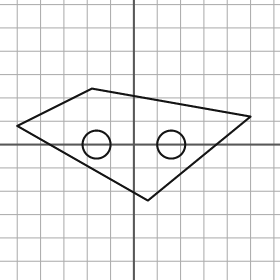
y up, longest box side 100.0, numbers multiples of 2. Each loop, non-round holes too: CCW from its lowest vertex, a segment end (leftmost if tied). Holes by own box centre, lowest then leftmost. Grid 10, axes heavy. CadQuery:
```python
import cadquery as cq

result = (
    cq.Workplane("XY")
    .moveTo(6.0, -24.0)
    .lineTo(50.0, 12.0)
    .lineTo(-18.0, 24.0)
    .lineTo(-50.0, 8.0)
    .close()
    .moveTo(-16.0, 0.0)
    .circle(6.0)
    .moveTo(16.0, 0.0)
    .circle(6.0)
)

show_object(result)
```